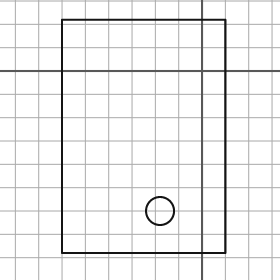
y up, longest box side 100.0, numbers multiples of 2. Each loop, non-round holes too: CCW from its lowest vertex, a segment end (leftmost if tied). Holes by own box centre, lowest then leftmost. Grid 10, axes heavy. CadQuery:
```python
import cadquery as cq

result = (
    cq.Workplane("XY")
    .moveTo(-60.0, -78.0)
    .lineTo(10.0, -78.0)
    .lineTo(10.0, 22.0)
    .lineTo(-60.0, 22.0)
    .close()
    .moveTo(-18.0, -60.0)
    .circle(6.0)
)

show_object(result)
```